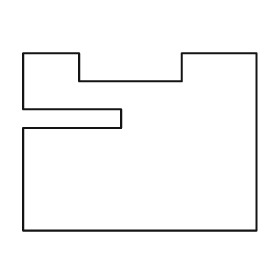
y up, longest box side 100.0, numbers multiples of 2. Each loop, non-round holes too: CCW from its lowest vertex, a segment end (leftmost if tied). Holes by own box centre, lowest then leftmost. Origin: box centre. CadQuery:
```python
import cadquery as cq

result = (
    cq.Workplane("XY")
    .moveTo(-50.0, -38.0)
    .lineTo(50.0, -38.0)
    .lineTo(50.0, 38.0)
    .lineTo(18.0, 38.0)
    .lineTo(18.0, 26.0)
    .lineTo(-26.0, 26.0)
    .lineTo(-26.0, 38.0)
    .lineTo(-50.0, 38.0)
    .lineTo(-50.0, 14.0)
    .lineTo(-8.0, 14.0)
    .lineTo(-8.0, 6.0)
    .lineTo(-50.0, 6.0)
    .close()
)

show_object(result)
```